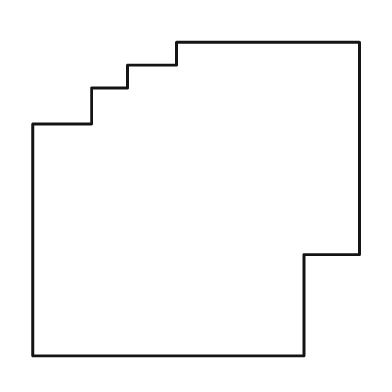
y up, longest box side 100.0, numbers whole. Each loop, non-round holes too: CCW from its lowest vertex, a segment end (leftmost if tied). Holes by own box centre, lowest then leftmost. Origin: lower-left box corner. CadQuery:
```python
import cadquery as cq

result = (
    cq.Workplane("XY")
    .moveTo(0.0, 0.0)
    .lineTo(83.0, 0.0)
    .lineTo(83.0, 31.0)
    .lineTo(100.0, 31.0)
    .lineTo(100.0, 96.0)
    .lineTo(44.0, 96.0)
    .lineTo(44.0, 89.0)
    .lineTo(29.0, 89.0)
    .lineTo(29.0, 82.0)
    .lineTo(18.0, 82.0)
    .lineTo(18.0, 71.0)
    .lineTo(0.0, 71.0)
    .close()
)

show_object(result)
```